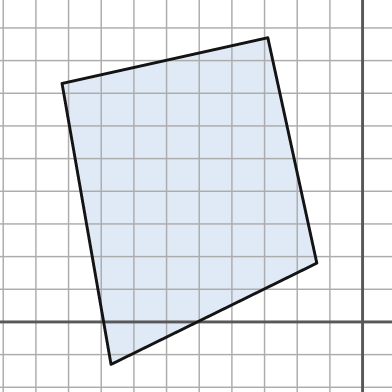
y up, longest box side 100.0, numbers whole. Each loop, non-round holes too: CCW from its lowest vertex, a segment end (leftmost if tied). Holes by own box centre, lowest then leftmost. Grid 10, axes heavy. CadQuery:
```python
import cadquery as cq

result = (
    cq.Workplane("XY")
    .moveTo(-77.0, -13.0)
    .lineTo(-14.0, 18.0)
    .lineTo(-29.0, 87.0)
    .lineTo(-92.0, 73.0)
    .close()
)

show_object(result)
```